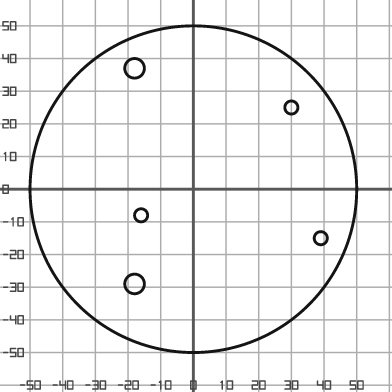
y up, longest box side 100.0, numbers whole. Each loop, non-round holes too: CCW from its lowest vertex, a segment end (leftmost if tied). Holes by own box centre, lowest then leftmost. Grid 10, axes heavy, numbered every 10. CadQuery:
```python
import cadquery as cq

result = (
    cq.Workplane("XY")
    .moveTo(0.0, 0.0)
    .circle(50.0)
    .moveTo(-18.0, -29.0)
    .circle(3.0)
    .moveTo(39.0, -15.0)
    .circle(2.0)
    .moveTo(-16.0, -8.0)
    .circle(2.0)
    .moveTo(30.0, 25.0)
    .circle(2.0)
    .moveTo(-18.0, 37.0)
    .circle(3.0)
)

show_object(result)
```